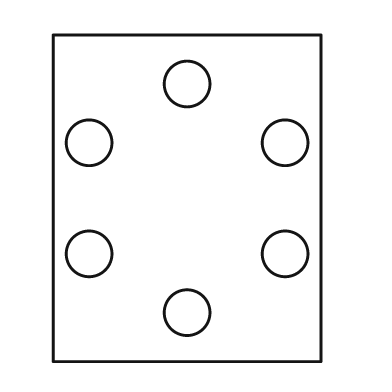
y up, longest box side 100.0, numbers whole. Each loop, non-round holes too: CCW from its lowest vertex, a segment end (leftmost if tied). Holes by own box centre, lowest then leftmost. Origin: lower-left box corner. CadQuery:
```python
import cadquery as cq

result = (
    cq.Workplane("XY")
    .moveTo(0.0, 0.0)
    .lineTo(82.0, 0.0)
    .lineTo(82.0, 100.0)
    .lineTo(0.0, 100.0)
    .close()
    .moveTo(41.0, 15.0)
    .circle(7.0)
    .moveTo(11.0, 33.0)
    .circle(7.0)
    .moveTo(71.0, 33.0)
    .circle(7.0)
    .moveTo(11.0, 67.0)
    .circle(7.0)
    .moveTo(71.0, 67.0)
    .circle(7.0)
    .moveTo(41.0, 85.0)
    .circle(7.0)
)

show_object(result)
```